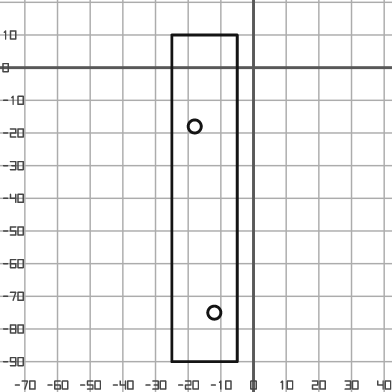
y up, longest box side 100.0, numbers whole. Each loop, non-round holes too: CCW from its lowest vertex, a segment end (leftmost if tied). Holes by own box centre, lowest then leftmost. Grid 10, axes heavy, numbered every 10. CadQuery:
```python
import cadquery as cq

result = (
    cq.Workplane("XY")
    .moveTo(-25.0, -90.0)
    .lineTo(-5.0, -90.0)
    .lineTo(-5.0, 10.0)
    .lineTo(-25.0, 10.0)
    .close()
    .moveTo(-12.0, -75.0)
    .circle(2.0)
    .moveTo(-18.0, -18.0)
    .circle(2.0)
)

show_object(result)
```